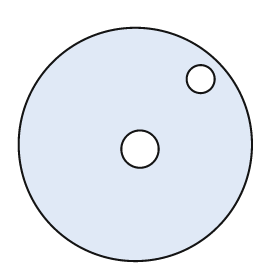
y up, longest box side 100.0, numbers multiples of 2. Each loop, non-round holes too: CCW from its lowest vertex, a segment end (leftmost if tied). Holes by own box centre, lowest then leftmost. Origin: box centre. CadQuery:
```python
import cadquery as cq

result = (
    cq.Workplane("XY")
    .moveTo(0.0, 0.0)
    .circle(50.0)
    .moveTo(2.0, -2.0)
    .circle(8.0)
    .moveTo(28.0, 28.0)
    .circle(6.0)
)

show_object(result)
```